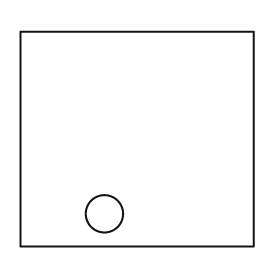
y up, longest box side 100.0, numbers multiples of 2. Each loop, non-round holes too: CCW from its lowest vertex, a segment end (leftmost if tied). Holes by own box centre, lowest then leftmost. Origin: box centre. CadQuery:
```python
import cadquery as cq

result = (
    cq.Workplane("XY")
    .moveTo(-50.0, -46.0)
    .lineTo(50.0, -46.0)
    .lineTo(50.0, 46.0)
    .lineTo(-50.0, 46.0)
    .close()
    .moveTo(-14.0, -32.0)
    .circle(8.0)
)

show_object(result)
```